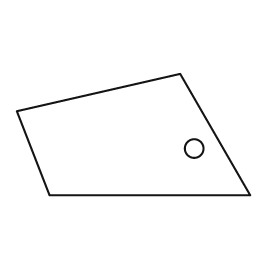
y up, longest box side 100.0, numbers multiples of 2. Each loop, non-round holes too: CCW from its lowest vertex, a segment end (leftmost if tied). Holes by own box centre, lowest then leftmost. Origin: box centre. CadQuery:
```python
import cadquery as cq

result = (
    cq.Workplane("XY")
    .moveTo(-36.0, -26.0)
    .lineTo(50.0, -26.0)
    .lineTo(20.0, 26.0)
    .lineTo(-50.0, 10.0)
    .close()
    .moveTo(26.0, -6.0)
    .circle(4.0)
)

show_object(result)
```